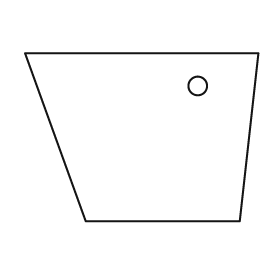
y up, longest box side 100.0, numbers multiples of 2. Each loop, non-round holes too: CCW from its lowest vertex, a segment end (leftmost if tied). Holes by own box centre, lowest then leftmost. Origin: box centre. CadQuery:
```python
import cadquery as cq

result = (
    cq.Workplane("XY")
    .moveTo(-24.0, -36.0)
    .lineTo(42.0, -36.0)
    .lineTo(50.0, 36.0)
    .lineTo(-50.0, 36.0)
    .close()
    .moveTo(24.0, 22.0)
    .circle(4.0)
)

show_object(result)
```